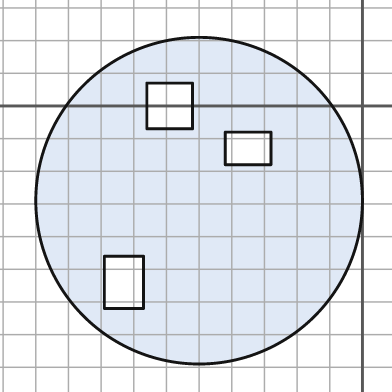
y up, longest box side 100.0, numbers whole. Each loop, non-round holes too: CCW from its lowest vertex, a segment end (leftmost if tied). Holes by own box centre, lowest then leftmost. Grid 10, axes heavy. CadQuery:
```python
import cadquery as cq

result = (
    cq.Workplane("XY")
    .moveTo(-50.0, -29.0)
    .circle(50.0)
    .moveTo(-79.0, -62.0)
    .lineTo(-67.0, -62.0)
    .lineTo(-67.0, -46.0)
    .lineTo(-79.0, -46.0)
    .close()
    .moveTo(-42.0, -18.0)
    .lineTo(-28.0, -18.0)
    .lineTo(-28.0, -8.0)
    .lineTo(-42.0, -8.0)
    .close()
    .moveTo(-66.0, -7.0)
    .lineTo(-52.0, -7.0)
    .lineTo(-52.0, 7.0)
    .lineTo(-66.0, 7.0)
    .close()
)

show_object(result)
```